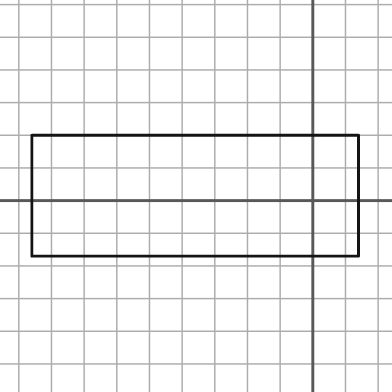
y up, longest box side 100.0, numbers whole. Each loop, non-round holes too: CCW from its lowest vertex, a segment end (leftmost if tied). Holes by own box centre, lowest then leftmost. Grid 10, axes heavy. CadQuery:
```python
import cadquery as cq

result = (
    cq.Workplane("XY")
    .moveTo(-86.0, -17.0)
    .lineTo(14.0, -17.0)
    .lineTo(14.0, 20.0)
    .lineTo(-86.0, 20.0)
    .close()
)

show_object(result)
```